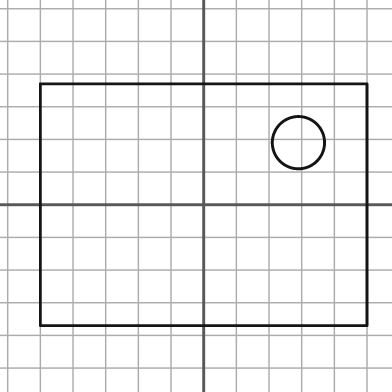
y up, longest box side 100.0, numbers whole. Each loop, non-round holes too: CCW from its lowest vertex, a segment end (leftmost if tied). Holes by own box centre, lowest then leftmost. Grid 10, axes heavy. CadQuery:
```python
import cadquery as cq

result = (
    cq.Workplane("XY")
    .moveTo(-50.0, -37.0)
    .lineTo(50.0, -37.0)
    .lineTo(50.0, 37.0)
    .lineTo(-50.0, 37.0)
    .close()
    .moveTo(29.0, 19.0)
    .circle(8.0)
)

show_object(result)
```